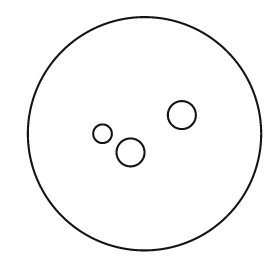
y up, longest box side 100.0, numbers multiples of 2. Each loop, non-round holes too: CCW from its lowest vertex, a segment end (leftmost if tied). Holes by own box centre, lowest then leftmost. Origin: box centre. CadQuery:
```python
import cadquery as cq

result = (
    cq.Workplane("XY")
    .moveTo(0.0, 0.0)
    .circle(50.0)
    .moveTo(-6.0, -8.0)
    .circle(6.0)
    .moveTo(-18.0, 0.0)
    .circle(4.0)
    .moveTo(16.0, 8.0)
    .circle(6.0)
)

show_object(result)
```